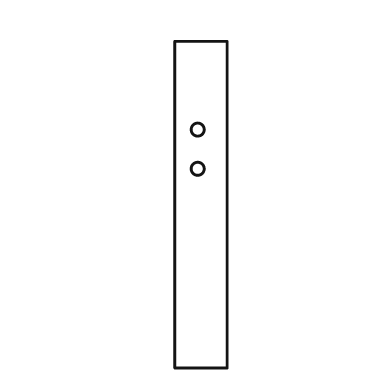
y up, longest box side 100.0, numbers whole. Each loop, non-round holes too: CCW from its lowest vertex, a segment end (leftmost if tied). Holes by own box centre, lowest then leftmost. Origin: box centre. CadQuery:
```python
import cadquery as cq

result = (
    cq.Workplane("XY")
    .moveTo(-8.0, -50.0)
    .lineTo(8.0, -50.0)
    .lineTo(8.0, 50.0)
    .lineTo(-8.0, 50.0)
    .close()
    .moveTo(-1.0, 11.0)
    .circle(2.0)
    .moveTo(-1.0, 23.0)
    .circle(2.0)
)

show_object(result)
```